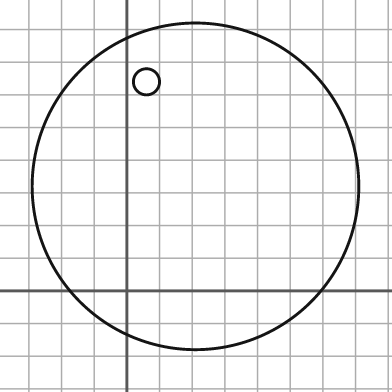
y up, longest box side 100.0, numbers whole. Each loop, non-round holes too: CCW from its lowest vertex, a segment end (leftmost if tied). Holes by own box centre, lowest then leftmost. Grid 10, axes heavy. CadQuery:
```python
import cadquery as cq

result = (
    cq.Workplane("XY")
    .moveTo(21.0, 32.0)
    .circle(50.0)
    .moveTo(6.0, 64.0)
    .circle(4.0)
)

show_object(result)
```